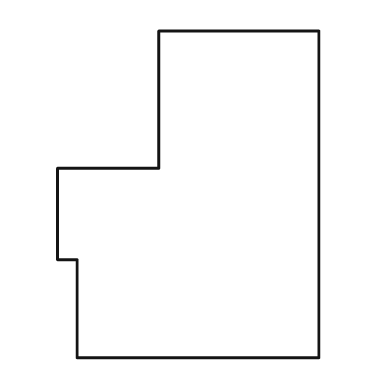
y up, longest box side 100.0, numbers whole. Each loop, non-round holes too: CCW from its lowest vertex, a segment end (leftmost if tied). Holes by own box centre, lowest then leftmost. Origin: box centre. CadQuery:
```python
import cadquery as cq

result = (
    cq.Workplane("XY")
    .moveTo(-34.0, -50.0)
    .lineTo(40.0, -50.0)
    .lineTo(40.0, 50.0)
    .lineTo(-9.0, 50.0)
    .lineTo(-9.0, 8.0)
    .lineTo(-40.0, 8.0)
    .lineTo(-40.0, -20.0)
    .lineTo(-34.0, -20.0)
    .close()
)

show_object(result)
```